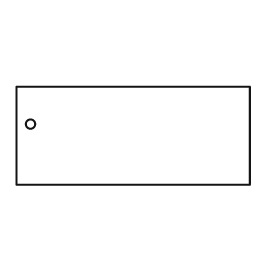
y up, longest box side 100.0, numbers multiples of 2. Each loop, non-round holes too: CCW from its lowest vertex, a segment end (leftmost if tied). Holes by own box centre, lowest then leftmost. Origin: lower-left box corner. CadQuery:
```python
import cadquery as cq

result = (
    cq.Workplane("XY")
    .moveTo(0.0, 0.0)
    .lineTo(100.0, 0.0)
    .lineTo(100.0, 42.0)
    .lineTo(0.0, 42.0)
    .close()
    .moveTo(6.0, 26.0)
    .circle(2.0)
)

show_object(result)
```